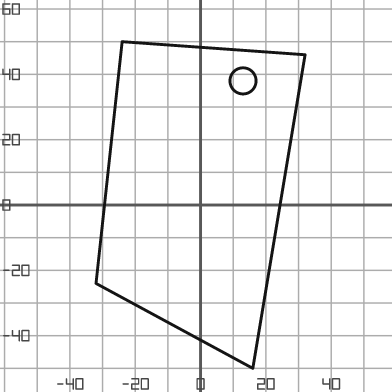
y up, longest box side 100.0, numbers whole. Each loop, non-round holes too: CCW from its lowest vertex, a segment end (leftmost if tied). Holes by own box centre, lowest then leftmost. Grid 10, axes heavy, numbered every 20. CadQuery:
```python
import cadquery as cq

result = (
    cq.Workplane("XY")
    .moveTo(16.0, -50.0)
    .lineTo(32.0, 46.0)
    .lineTo(-24.0, 50.0)
    .lineTo(-32.0, -24.0)
    .close()
    .moveTo(13.0, 38.0)
    .circle(4.0)
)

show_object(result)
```